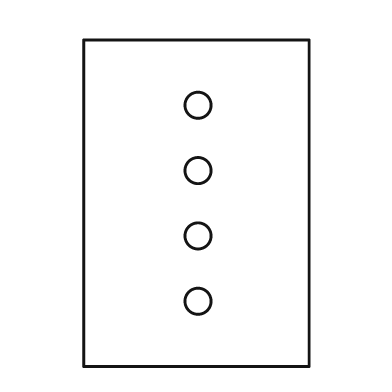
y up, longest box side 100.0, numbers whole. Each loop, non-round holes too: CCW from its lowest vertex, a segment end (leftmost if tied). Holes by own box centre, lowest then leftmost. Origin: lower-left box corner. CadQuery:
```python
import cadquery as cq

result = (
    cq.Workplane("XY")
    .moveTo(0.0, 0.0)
    .lineTo(69.0, 0.0)
    .lineTo(69.0, 100.0)
    .lineTo(0.0, 100.0)
    .close()
    .moveTo(35.0, 20.0)
    .circle(4.0)
    .moveTo(35.0, 40.0)
    .circle(4.0)
    .moveTo(35.0, 60.0)
    .circle(4.0)
    .moveTo(35.0, 80.0)
    .circle(4.0)
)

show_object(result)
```